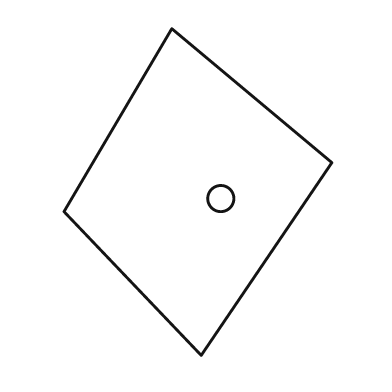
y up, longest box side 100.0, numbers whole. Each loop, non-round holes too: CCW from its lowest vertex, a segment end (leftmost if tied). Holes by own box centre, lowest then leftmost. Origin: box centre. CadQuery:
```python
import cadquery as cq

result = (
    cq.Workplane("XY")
    .moveTo(1.0, -50.0)
    .lineTo(41.0, 9.0)
    .lineTo(-8.0, 50.0)
    .lineTo(-41.0, -6.0)
    .close()
    .moveTo(7.0, -2.0)
    .circle(4.0)
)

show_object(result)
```